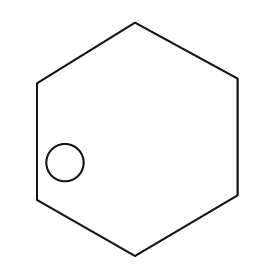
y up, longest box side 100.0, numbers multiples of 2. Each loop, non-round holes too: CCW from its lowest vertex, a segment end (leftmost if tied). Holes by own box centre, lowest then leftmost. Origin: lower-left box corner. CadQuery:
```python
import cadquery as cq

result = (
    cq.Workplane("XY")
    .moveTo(42.0, 0.0)
    .lineTo(86.0, 26.0)
    .lineTo(86.0, 76.0)
    .lineTo(42.0, 100.0)
    .lineTo(0.0, 74.0)
    .lineTo(0.0, 24.0)
    .close()
    .moveTo(12.0, 40.0)
    .circle(8.0)
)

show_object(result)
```